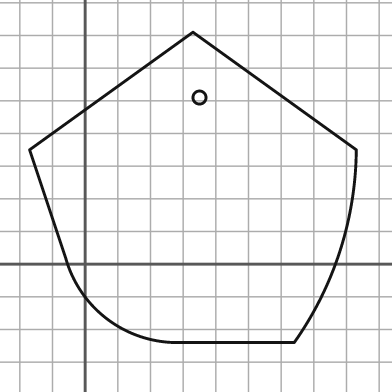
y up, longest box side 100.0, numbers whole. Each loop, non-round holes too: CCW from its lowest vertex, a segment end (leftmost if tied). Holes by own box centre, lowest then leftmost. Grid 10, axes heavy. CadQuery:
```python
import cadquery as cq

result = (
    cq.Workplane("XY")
    .moveTo(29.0, -24.0)
    .lineTo(64.0, -24.0)
    .threePointArc((78.0, 4.0), (83.0, 35.0))
    .lineTo(33.0, 71.0)
    .lineTo(-17.0, 35.0)
    .lineTo(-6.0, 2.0)
    .threePointArc((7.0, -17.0), (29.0, -24.0))
    .close()
    .moveTo(35.0, 51.0)
    .circle(2.0)
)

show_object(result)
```